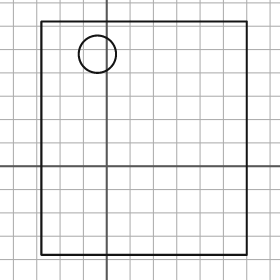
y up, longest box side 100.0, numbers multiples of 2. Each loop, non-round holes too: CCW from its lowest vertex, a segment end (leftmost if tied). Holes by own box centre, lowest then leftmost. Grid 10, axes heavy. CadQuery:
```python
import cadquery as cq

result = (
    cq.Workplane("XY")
    .moveTo(-28.0, -38.0)
    .lineTo(60.0, -38.0)
    .lineTo(60.0, 62.0)
    .lineTo(-28.0, 62.0)
    .close()
    .moveTo(-4.0, 48.0)
    .circle(8.0)
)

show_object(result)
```